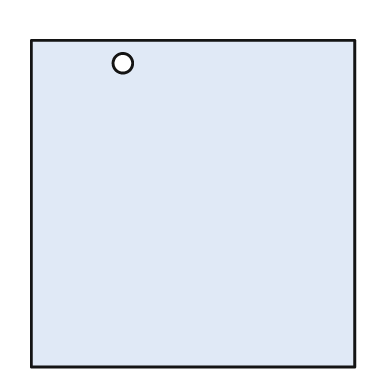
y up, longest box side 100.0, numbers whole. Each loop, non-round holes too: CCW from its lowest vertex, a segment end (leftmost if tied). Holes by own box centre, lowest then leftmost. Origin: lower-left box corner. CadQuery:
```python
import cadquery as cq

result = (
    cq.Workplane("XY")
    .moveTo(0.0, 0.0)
    .lineTo(99.0, 0.0)
    .lineTo(99.0, 100.0)
    .lineTo(0.0, 100.0)
    .close()
    .moveTo(28.0, 93.0)
    .circle(3.0)
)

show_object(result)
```